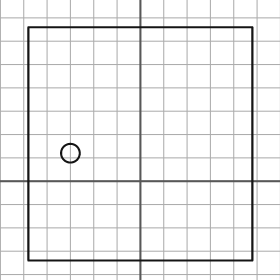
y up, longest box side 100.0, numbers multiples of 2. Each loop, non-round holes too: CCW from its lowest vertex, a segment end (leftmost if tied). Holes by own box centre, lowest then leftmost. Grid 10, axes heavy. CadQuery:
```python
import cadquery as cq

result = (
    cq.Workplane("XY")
    .moveTo(-48.0, -34.0)
    .lineTo(48.0, -34.0)
    .lineTo(48.0, 66.0)
    .lineTo(-48.0, 66.0)
    .close()
    .moveTo(-30.0, 12.0)
    .circle(4.0)
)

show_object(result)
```